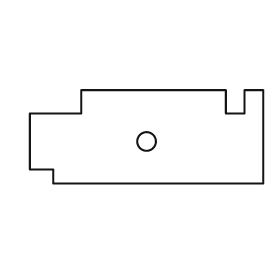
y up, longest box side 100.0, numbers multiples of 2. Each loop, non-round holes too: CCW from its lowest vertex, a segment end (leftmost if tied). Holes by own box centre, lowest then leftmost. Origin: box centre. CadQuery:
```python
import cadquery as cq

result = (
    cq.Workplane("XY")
    .moveTo(-40.0, -20.0)
    .lineTo(50.0, -20.0)
    .lineTo(50.0, 20.0)
    .lineTo(42.0, 20.0)
    .lineTo(42.0, 10.0)
    .lineTo(34.0, 10.0)
    .lineTo(34.0, 20.0)
    .lineTo(-28.0, 20.0)
    .lineTo(-28.0, 10.0)
    .lineTo(-50.0, 10.0)
    .lineTo(-50.0, -14.0)
    .lineTo(-40.0, -14.0)
    .close()
    .moveTo(0.0, -2.0)
    .circle(4.0)
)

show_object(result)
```